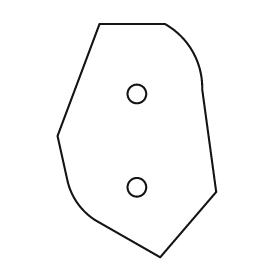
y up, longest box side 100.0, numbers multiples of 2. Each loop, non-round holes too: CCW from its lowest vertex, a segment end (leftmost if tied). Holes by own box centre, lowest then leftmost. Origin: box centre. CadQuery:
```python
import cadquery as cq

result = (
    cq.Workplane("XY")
    .moveTo(10.0, -50.0)
    .lineTo(34.0, -22.0)
    .lineTo(28.0, 22.0)
    .threePointArc((24.0, 38.0), (12.0, 50.0))
    .lineTo(-16.0, 50.0)
    .lineTo(-34.0, 2.0)
    .lineTo(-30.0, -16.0)
    .threePointArc((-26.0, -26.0), (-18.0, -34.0))
    .close()
    .moveTo(0.0, -20.0)
    .circle(4.0)
    .moveTo(0.0, 20.0)
    .circle(4.0)
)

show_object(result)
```